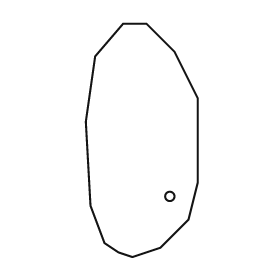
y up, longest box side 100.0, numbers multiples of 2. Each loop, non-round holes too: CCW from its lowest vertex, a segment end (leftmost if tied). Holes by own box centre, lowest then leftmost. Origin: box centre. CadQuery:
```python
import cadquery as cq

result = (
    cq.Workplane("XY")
    .moveTo(-4.0, -50.0)
    .lineTo(8.0, -46.0)
    .lineTo(20.0, -34.0)
    .lineTo(24.0, -18.0)
    .lineTo(24.0, 18.0)
    .lineTo(14.0, 38.0)
    .lineTo(2.0, 50.0)
    .lineTo(-8.0, 50.0)
    .lineTo(-20.0, 36.0)
    .lineTo(-24.0, 8.0)
    .lineTo(-22.0, -28.0)
    .lineTo(-16.0, -44.0)
    .lineTo(-10.0, -48.0)
    .close()
    .moveTo(12.0, -24.0)
    .circle(2.0)
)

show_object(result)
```